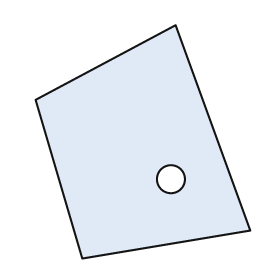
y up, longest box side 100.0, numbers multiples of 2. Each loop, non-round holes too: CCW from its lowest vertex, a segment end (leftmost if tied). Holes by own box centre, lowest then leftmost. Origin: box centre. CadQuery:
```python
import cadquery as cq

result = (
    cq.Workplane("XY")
    .moveTo(-26.0, -50.0)
    .lineTo(46.0, -38.0)
    .lineTo(14.0, 50.0)
    .lineTo(-46.0, 18.0)
    .close()
    .moveTo(12.0, -16.0)
    .circle(6.0)
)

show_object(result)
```